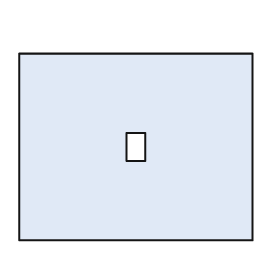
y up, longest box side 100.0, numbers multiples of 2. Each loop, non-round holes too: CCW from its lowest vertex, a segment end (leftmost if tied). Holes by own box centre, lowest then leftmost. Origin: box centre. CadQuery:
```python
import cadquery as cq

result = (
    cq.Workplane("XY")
    .moveTo(-50.0, -40.0)
    .lineTo(50.0, -40.0)
    .lineTo(50.0, 40.0)
    .lineTo(-50.0, 40.0)
    .close()
    .moveTo(-4.0, -6.0)
    .lineTo(4.0, -6.0)
    .lineTo(4.0, 6.0)
    .lineTo(-4.0, 6.0)
    .close()
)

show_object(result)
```